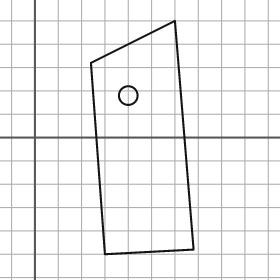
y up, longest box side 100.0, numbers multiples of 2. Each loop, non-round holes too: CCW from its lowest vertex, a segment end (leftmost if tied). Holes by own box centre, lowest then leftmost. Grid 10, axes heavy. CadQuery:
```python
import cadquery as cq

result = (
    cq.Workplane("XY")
    .moveTo(30.0, -50.0)
    .lineTo(68.0, -48.0)
    .lineTo(60.0, 50.0)
    .lineTo(24.0, 32.0)
    .close()
    .moveTo(40.0, 18.0)
    .circle(4.0)
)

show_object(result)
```